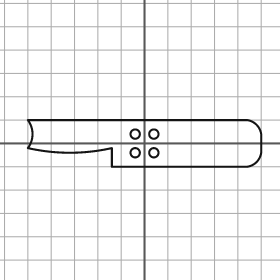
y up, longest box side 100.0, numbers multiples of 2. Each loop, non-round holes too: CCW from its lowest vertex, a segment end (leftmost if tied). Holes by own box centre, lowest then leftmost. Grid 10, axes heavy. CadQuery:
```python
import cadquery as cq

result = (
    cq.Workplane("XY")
    .moveTo(-14.0, -10.0)
    .lineTo(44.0, -10.0)
    .threePointArc((48.0, -8.0), (50.0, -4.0))
    .lineTo(50.0, 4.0)
    .threePointArc((48.0, 8.0), (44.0, 10.0))
    .lineTo(-50.0, 10.0)
    .threePointArc((-48.0, 4.0), (-50.0, -2.0))
    .threePointArc((-32.0, -4.0), (-14.0, -2.0))
    .close()
    .moveTo(-4.0, -4.0)
    .circle(2.0)
    .moveTo(4.0, -4.0)
    .circle(2.0)
    .moveTo(-4.0, 4.0)
    .circle(2.0)
    .moveTo(4.0, 4.0)
    .circle(2.0)
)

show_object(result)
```